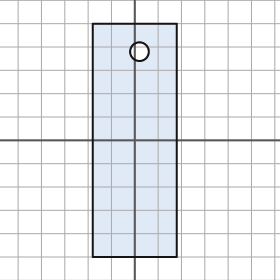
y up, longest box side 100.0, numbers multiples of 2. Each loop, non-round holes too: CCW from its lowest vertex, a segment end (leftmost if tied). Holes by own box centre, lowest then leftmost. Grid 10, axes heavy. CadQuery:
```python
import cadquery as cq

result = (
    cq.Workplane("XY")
    .moveTo(-18.0, -50.0)
    .lineTo(18.0, -50.0)
    .lineTo(18.0, 50.0)
    .lineTo(-18.0, 50.0)
    .close()
    .moveTo(2.0, 38.0)
    .circle(4.0)
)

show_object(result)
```